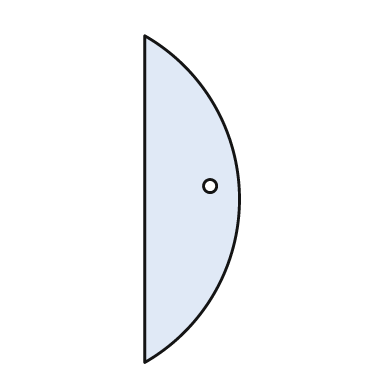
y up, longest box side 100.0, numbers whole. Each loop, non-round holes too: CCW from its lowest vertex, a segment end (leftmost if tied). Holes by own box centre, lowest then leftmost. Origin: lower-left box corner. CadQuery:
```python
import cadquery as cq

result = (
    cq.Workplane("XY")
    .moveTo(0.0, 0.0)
    .threePointArc((29.0, 50.0), (0.0, 100.0))
    .close()
    .moveTo(20.0, 54.0)
    .circle(2.0)
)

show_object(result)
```